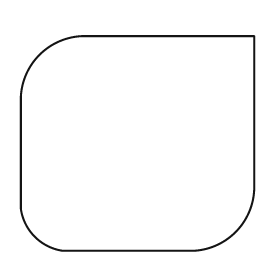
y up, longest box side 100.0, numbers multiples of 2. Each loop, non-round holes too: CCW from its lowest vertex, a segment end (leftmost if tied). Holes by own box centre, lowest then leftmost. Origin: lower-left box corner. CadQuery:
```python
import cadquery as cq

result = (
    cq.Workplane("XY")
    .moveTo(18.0, 0.0)
    .lineTo(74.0, 0.0)
    .threePointArc((92.0, 8.0), (100.0, 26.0))
    .lineTo(100.0, 92.0)
    .lineTo(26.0, 92.0)
    .threePointArc((8.0, 84.0), (0.0, 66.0))
    .lineTo(0.0, 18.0)
    .threePointArc((6.0, 6.0), (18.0, 0.0))
    .close()
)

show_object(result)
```